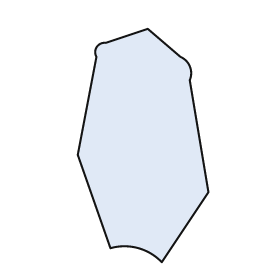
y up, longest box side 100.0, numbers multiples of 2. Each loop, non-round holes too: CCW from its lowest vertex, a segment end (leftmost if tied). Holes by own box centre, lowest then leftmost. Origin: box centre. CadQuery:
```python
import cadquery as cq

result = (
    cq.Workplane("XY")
    .moveTo(8.0, -50.0)
    .lineTo(28.0, -20.0)
    .lineTo(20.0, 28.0)
    .threePointArc((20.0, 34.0), (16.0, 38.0))
    .lineTo(2.0, 50.0)
    .lineTo(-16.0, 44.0)
    .threePointArc((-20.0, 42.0), (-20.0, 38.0))
    .lineTo(-28.0, -4.0)
    .lineTo(-14.0, -44.0)
    .threePointArc((-2.0, -44.0), (8.0, -50.0))
    .close()
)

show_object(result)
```